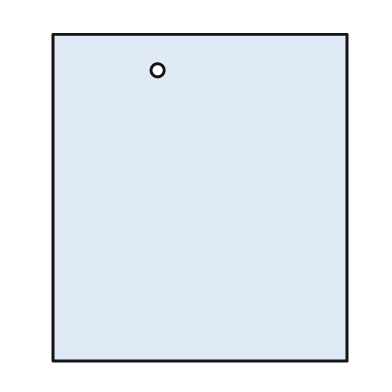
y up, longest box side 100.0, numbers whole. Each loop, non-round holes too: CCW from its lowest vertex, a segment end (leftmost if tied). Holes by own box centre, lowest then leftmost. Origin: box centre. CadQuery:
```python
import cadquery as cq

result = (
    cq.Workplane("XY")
    .moveTo(-45.0, -50.0)
    .lineTo(45.0, -50.0)
    .lineTo(45.0, 50.0)
    .lineTo(-45.0, 50.0)
    .close()
    .moveTo(-13.0, 39.0)
    .circle(2.0)
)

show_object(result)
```